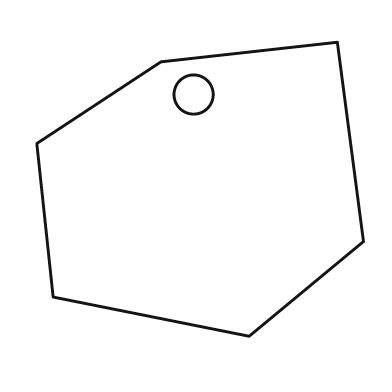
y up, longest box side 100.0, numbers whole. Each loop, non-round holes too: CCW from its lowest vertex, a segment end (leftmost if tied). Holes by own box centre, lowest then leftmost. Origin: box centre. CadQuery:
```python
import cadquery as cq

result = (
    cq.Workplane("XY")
    .moveTo(15.0, -45.0)
    .lineTo(50.0, -16.0)
    .lineTo(42.0, 45.0)
    .lineTo(-12.0, 39.0)
    .lineTo(-50.0, 14.0)
    .lineTo(-45.0, -33.0)
    .close()
    .moveTo(-2.0, 29.0)
    .circle(6.0)
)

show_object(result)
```